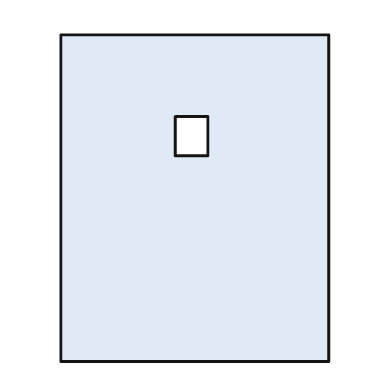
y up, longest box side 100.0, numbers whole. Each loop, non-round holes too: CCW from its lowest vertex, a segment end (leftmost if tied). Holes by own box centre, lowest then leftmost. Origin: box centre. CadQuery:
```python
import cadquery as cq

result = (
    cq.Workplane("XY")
    .moveTo(-41.0, -50.0)
    .lineTo(41.0, -50.0)
    .lineTo(41.0, 50.0)
    .lineTo(-41.0, 50.0)
    .close()
    .moveTo(-6.0, 13.0)
    .lineTo(4.0, 13.0)
    .lineTo(4.0, 25.0)
    .lineTo(-6.0, 25.0)
    .close()
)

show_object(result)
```